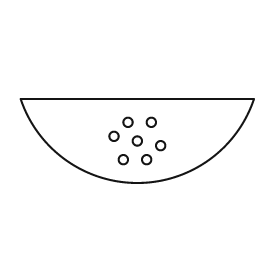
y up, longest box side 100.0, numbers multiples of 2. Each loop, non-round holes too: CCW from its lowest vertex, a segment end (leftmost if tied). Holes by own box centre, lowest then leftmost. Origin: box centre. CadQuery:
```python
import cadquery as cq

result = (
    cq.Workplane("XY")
    .moveTo(-50.0, 18.0)
    .threePointArc((0.0, -18.0), (50.0, 18.0))
    .close()
    .moveTo(-6.0, -8.0)
    .circle(2.0)
    .moveTo(4.0, -8.0)
    .circle(2.0)
    .moveTo(10.0, -2.0)
    .circle(2.0)
    .moveTo(0.0, 0.0)
    .circle(2.0)
    .moveTo(-10.0, 2.0)
    .circle(2.0)
    .moveTo(-4.0, 8.0)
    .circle(2.0)
    .moveTo(6.0, 8.0)
    .circle(2.0)
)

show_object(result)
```